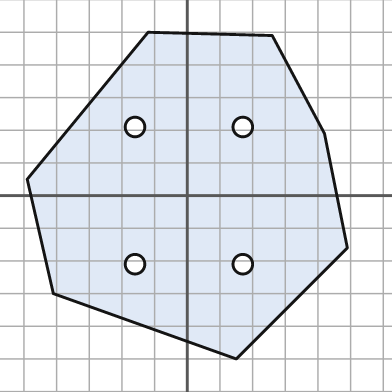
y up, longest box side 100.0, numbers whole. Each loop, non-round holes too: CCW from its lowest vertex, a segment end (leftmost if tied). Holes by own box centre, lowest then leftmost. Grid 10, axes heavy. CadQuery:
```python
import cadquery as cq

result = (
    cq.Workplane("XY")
    .moveTo(15.0, -50.0)
    .lineTo(49.0, -16.0)
    .lineTo(42.0, 19.0)
    .lineTo(26.0, 49.0)
    .lineTo(-12.0, 50.0)
    .lineTo(-49.0, 5.0)
    .lineTo(-41.0, -30.0)
    .close()
    .moveTo(-16.0, -21.0)
    .circle(3.0)
    .moveTo(17.0, -21.0)
    .circle(3.0)
    .moveTo(-16.0, 21.0)
    .circle(3.0)
    .moveTo(17.0, 21.0)
    .circle(3.0)
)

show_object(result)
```